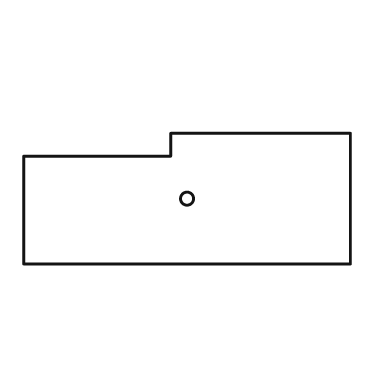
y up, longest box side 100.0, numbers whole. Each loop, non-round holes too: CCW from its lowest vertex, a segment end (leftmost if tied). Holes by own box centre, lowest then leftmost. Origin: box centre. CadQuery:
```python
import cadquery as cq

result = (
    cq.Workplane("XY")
    .moveTo(-50.0, -20.0)
    .lineTo(50.0, -20.0)
    .lineTo(50.0, 20.0)
    .lineTo(-5.0, 20.0)
    .lineTo(-5.0, 13.0)
    .lineTo(-50.0, 13.0)
    .close()
    .moveTo(0.0, 0.0)
    .circle(2.0)
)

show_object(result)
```